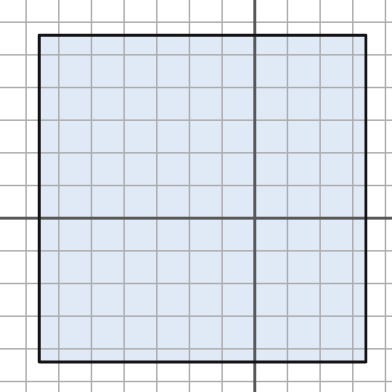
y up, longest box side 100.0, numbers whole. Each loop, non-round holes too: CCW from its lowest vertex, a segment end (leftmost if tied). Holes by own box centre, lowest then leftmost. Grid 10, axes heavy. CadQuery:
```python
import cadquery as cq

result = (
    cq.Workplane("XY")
    .moveTo(-66.0, -44.0)
    .lineTo(34.0, -44.0)
    .lineTo(34.0, 56.0)
    .lineTo(-66.0, 56.0)
    .close()
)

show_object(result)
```